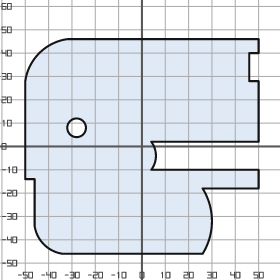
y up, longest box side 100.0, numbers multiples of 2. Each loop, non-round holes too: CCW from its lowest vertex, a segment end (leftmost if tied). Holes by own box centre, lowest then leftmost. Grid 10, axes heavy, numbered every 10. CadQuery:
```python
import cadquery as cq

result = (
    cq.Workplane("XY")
    .moveTo(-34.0, -46.0)
    .lineTo(26.0, -46.0)
    .threePointArc((30.0, -32.0), (26.0, -18.0))
    .lineTo(50.0, -18.0)
    .lineTo(50.0, -10.0)
    .lineTo(4.0, -10.0)
    .threePointArc((6.0, -4.0), (4.0, 2.0))
    .lineTo(50.0, 2.0)
    .lineTo(50.0, 28.0)
    .lineTo(46.0, 28.0)
    .lineTo(46.0, 40.0)
    .lineTo(50.0, 40.0)
    .lineTo(50.0, 46.0)
    .lineTo(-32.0, 46.0)
    .threePointArc((-44.0, 40.0), (-50.0, 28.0))
    .lineTo(-50.0, -14.0)
    .lineTo(-46.0, -14.0)
    .lineTo(-46.0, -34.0)
    .threePointArc((-42.0, -42.0), (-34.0, -46.0))
    .close()
    .moveTo(-28.0, 8.0)
    .circle(4.0)
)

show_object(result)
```